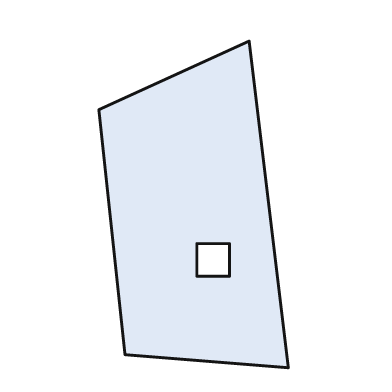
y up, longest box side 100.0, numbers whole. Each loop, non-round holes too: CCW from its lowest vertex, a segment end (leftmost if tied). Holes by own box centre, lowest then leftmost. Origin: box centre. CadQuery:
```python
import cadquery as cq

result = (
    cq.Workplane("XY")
    .moveTo(29.0, -50.0)
    .lineTo(17.0, 50.0)
    .lineTo(-29.0, 29.0)
    .lineTo(-21.0, -46.0)
    .close()
    .moveTo(1.0, -22.0)
    .lineTo(11.0, -22.0)
    .lineTo(11.0, -12.0)
    .lineTo(1.0, -12.0)
    .close()
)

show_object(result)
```